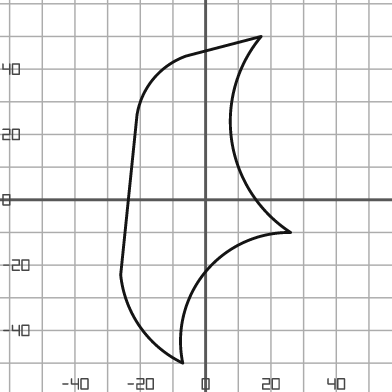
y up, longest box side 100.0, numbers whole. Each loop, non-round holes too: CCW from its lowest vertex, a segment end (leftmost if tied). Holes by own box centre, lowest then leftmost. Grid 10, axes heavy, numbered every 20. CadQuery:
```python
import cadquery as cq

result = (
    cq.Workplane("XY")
    .moveTo(-7.0, -50.0)
    .threePointArc((0.0, -22.0), (26.0, -10.0))
    .threePointArc((8.0, 18.0), (17.0, 50.0))
    .lineTo(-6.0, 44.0)
    .threePointArc((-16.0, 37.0), (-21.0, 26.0))
    .lineTo(-26.0, -23.0)
    .threePointArc((-20.0, -39.0), (-7.0, -50.0))
    .close()
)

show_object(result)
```